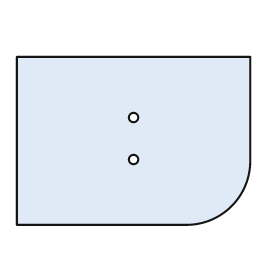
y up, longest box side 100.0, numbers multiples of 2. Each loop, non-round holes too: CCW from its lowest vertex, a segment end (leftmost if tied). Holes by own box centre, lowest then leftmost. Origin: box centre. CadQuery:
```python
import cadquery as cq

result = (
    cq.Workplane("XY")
    .moveTo(-50.0, -36.0)
    .lineTo(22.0, -36.0)
    .threePointArc((42.0, -28.0), (50.0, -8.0))
    .lineTo(50.0, 36.0)
    .lineTo(-50.0, 36.0)
    .close()
    .moveTo(0.0, -8.0)
    .circle(2.0)
    .moveTo(0.0, 10.0)
    .circle(2.0)
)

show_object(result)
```